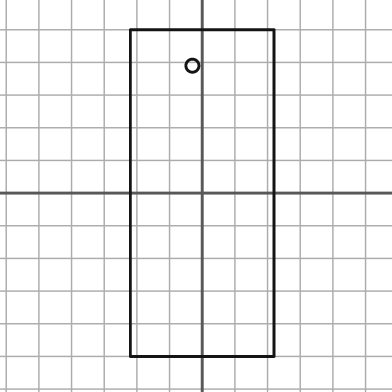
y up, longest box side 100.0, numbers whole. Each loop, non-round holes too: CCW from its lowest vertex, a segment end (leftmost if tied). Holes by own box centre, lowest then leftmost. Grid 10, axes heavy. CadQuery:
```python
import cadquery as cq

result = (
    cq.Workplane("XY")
    .moveTo(-22.0, -50.0)
    .lineTo(22.0, -50.0)
    .lineTo(22.0, 50.0)
    .lineTo(-22.0, 50.0)
    .close()
    .moveTo(-3.0, 39.0)
    .circle(2.0)
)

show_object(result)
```